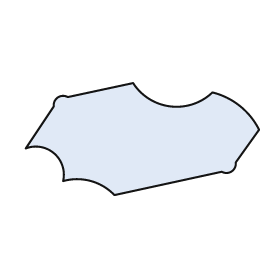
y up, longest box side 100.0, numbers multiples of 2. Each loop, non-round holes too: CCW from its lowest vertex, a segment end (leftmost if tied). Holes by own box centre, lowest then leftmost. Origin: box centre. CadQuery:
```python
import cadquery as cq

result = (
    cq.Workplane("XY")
    .moveTo(-12.0, -24.0)
    .lineTo(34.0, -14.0)
    .threePointArc((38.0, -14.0), (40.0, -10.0))
    .lineTo(50.0, 4.0)
    .threePointArc((42.0, 14.0), (30.0, 20.0))
    .threePointArc((12.0, 14.0), (-4.0, 24.0))
    .lineTo(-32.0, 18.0)
    .threePointArc((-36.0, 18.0), (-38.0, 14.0))
    .lineTo(-50.0, -4.0)
    .threePointArc((-38.0, -6.0), (-34.0, -18.0))
    .threePointArc((-22.0, -18.0), (-12.0, -24.0))
    .close()
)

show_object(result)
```